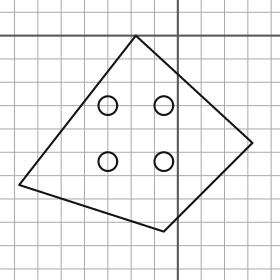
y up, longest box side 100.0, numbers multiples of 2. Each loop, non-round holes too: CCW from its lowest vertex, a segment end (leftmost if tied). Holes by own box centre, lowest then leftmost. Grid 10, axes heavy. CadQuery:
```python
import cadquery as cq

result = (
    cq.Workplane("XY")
    .moveTo(-6.0, -84.0)
    .lineTo(32.0, -46.0)
    .lineTo(-18.0, 0.0)
    .lineTo(-68.0, -64.0)
    .close()
    .moveTo(-30.0, -54.0)
    .circle(4.0)
    .moveTo(-6.0, -54.0)
    .circle(4.0)
    .moveTo(-30.0, -30.0)
    .circle(4.0)
    .moveTo(-6.0, -30.0)
    .circle(4.0)
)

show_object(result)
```